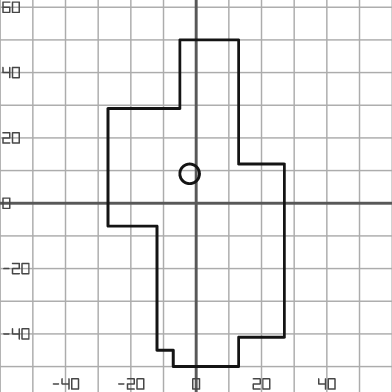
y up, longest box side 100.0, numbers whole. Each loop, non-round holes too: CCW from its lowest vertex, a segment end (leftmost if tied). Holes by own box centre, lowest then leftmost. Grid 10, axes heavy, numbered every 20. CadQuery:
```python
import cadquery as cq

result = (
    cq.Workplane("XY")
    .moveTo(-7.0, -50.0)
    .lineTo(13.0, -50.0)
    .lineTo(13.0, -41.0)
    .lineTo(27.0, -41.0)
    .lineTo(27.0, 12.0)
    .lineTo(13.0, 12.0)
    .lineTo(13.0, 50.0)
    .lineTo(-5.0, 50.0)
    .lineTo(-5.0, 29.0)
    .lineTo(-27.0, 29.0)
    .lineTo(-27.0, -7.0)
    .lineTo(-12.0, -7.0)
    .lineTo(-12.0, -45.0)
    .lineTo(-7.0, -45.0)
    .close()
    .moveTo(-2.0, 9.0)
    .circle(3.0)
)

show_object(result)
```